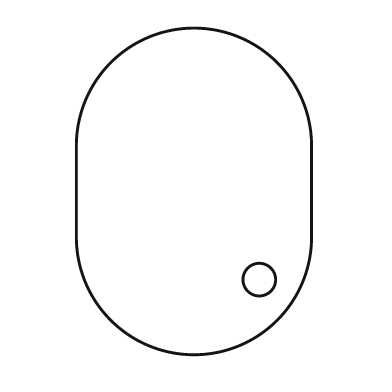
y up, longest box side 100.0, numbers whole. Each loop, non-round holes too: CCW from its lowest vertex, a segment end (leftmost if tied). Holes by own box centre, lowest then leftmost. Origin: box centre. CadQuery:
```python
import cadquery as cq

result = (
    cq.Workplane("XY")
    .moveTo(-36.0, -14.0)
    .threePointArc((0.0, -50.0), (36.0, -14.0))
    .lineTo(36.0, 14.0)
    .threePointArc((0.0, 50.0), (-36.0, 14.0))
    .close()
    .moveTo(20.0, -27.0)
    .circle(5.0)
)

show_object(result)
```